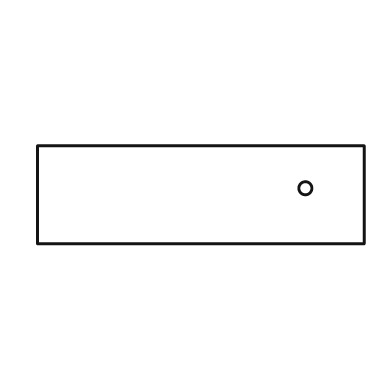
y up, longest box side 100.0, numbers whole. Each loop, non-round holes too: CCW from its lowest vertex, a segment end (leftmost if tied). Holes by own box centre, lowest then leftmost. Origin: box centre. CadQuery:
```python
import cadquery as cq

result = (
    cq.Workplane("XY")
    .moveTo(-50.0, -15.0)
    .lineTo(50.0, -15.0)
    .lineTo(50.0, 15.0)
    .lineTo(-50.0, 15.0)
    .close()
    .moveTo(32.0, 2.0)
    .circle(2.0)
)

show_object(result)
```